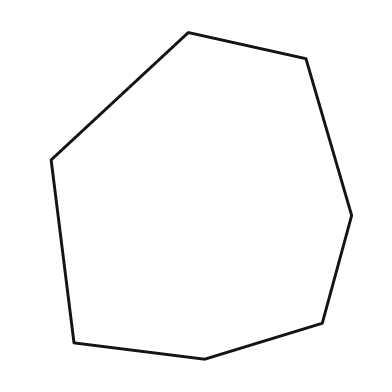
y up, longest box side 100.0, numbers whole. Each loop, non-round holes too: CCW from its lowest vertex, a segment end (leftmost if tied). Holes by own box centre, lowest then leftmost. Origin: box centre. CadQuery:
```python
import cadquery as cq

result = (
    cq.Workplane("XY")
    .moveTo(1.0, -50.0)
    .lineTo(37.0, -39.0)
    .lineTo(46.0, -6.0)
    .lineTo(32.0, 42.0)
    .lineTo(-4.0, 50.0)
    .lineTo(-46.0, 11.0)
    .lineTo(-39.0, -45.0)
    .close()
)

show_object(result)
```